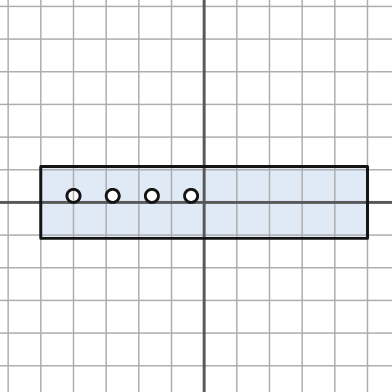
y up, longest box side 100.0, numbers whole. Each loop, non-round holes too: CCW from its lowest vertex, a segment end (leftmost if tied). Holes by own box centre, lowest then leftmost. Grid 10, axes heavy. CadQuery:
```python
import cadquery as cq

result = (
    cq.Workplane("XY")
    .moveTo(-50.0, -11.0)
    .lineTo(50.0, -11.0)
    .lineTo(50.0, 11.0)
    .lineTo(-50.0, 11.0)
    .close()
    .moveTo(-40.0, 2.0)
    .circle(2.0)
    .moveTo(-28.0, 2.0)
    .circle(2.0)
    .moveTo(-16.0, 2.0)
    .circle(2.0)
    .moveTo(-4.0, 2.0)
    .circle(2.0)
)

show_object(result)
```